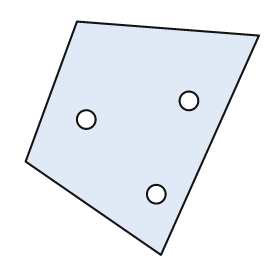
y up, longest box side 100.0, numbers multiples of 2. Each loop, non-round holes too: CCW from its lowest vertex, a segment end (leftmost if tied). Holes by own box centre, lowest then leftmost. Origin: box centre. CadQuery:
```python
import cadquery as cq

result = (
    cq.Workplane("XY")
    .moveTo(8.0, -50.0)
    .lineTo(50.0, 44.0)
    .lineTo(-28.0, 50.0)
    .lineTo(-50.0, -10.0)
    .close()
    .moveTo(6.0, -24.0)
    .circle(4.0)
    .moveTo(-24.0, 8.0)
    .circle(4.0)
    .moveTo(20.0, 16.0)
    .circle(4.0)
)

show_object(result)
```